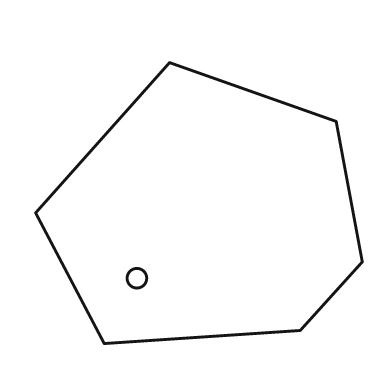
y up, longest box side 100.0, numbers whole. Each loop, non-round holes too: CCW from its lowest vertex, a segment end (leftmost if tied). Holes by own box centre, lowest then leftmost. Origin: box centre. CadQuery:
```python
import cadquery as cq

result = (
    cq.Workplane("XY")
    .moveTo(-29.0, -43.0)
    .lineTo(31.0, -39.0)
    .lineTo(50.0, -18.0)
    .lineTo(42.0, 25.0)
    .lineTo(-9.0, 43.0)
    .lineTo(-50.0, -3.0)
    .close()
    .moveTo(-19.0, -23.0)
    .circle(3.0)
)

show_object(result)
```